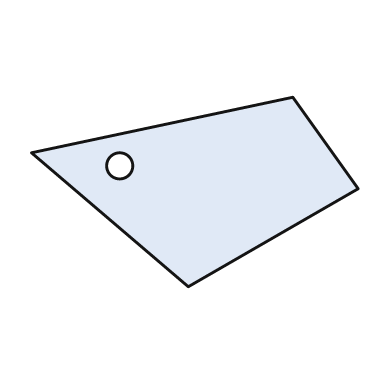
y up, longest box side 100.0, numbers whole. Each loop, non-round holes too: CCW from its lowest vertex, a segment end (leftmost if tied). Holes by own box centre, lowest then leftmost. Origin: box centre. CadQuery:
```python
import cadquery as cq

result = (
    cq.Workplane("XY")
    .moveTo(-2.0, -29.0)
    .lineTo(50.0, 1.0)
    .lineTo(30.0, 29.0)
    .lineTo(-50.0, 12.0)
    .close()
    .moveTo(-23.0, 8.0)
    .circle(4.0)
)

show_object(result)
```